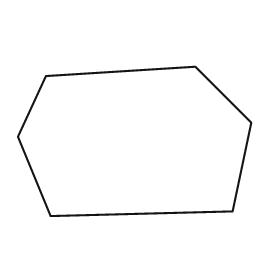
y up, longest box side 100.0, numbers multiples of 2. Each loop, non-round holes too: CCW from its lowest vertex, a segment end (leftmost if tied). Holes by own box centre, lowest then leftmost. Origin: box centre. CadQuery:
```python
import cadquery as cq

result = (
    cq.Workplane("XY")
    .moveTo(-36.0, -32.0)
    .lineTo(42.0, -30.0)
    .lineTo(50.0, 8.0)
    .lineTo(26.0, 32.0)
    .lineTo(-38.0, 28.0)
    .lineTo(-50.0, 2.0)
    .close()
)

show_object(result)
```